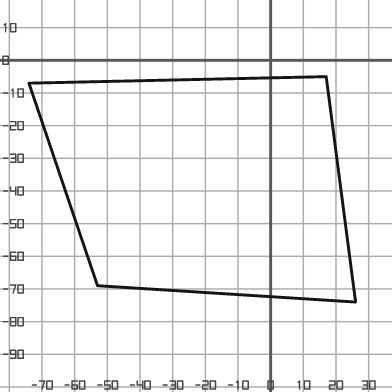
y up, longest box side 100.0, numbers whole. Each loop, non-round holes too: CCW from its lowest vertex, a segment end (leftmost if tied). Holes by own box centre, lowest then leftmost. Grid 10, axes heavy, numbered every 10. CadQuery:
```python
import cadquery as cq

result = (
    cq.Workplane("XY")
    .moveTo(26.0, -74.0)
    .lineTo(17.0, -5.0)
    .lineTo(-74.0, -7.0)
    .lineTo(-53.0, -69.0)
    .close()
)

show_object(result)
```